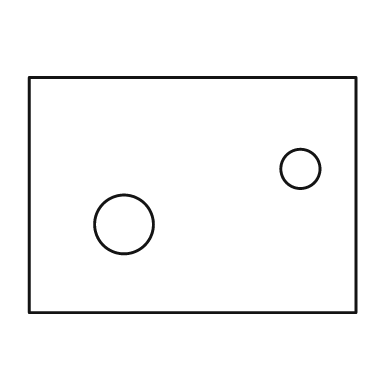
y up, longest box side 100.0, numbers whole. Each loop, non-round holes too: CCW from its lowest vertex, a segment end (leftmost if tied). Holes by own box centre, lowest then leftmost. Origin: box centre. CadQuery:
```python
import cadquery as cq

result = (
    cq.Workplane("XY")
    .moveTo(-50.0, -36.0)
    .lineTo(50.0, -36.0)
    .lineTo(50.0, 36.0)
    .lineTo(-50.0, 36.0)
    .close()
    .moveTo(-21.0, -9.0)
    .circle(9.0)
    .moveTo(33.0, 8.0)
    .circle(6.0)
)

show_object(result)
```